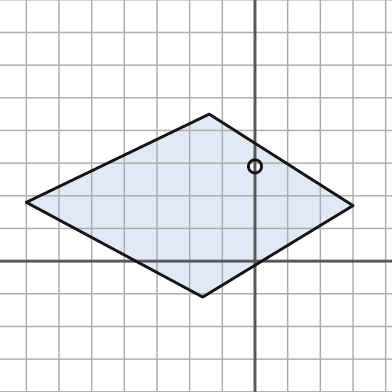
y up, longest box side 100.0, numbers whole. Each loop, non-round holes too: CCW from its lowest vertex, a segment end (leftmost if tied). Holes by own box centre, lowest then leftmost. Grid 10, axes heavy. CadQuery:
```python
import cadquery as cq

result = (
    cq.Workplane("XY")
    .moveTo(-16.0, -11.0)
    .lineTo(30.0, 17.0)
    .lineTo(-14.0, 45.0)
    .lineTo(-70.0, 18.0)
    .close()
    .moveTo(0.0, 29.0)
    .circle(2.0)
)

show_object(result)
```